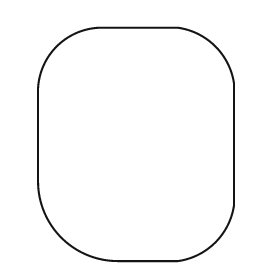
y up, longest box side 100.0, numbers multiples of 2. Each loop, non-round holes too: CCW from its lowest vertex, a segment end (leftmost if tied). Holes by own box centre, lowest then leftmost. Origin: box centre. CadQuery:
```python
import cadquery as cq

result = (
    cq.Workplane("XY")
    .moveTo(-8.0, -50.0)
    .lineTo(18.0, -50.0)
    .threePointArc((34.0, -42.0), (42.0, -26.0))
    .lineTo(42.0, 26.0)
    .threePointArc((34.0, 42.0), (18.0, 50.0))
    .lineTo(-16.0, 50.0)
    .threePointArc((-34.0, 42.0), (-42.0, 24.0))
    .lineTo(-42.0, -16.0)
    .threePointArc((-32.0, -40.0), (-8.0, -50.0))
    .close()
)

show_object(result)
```